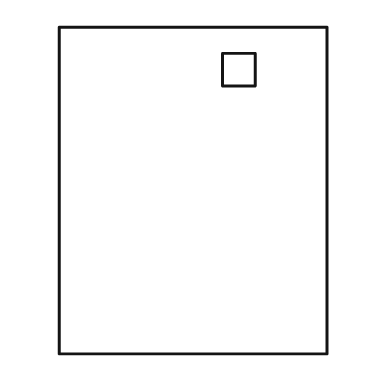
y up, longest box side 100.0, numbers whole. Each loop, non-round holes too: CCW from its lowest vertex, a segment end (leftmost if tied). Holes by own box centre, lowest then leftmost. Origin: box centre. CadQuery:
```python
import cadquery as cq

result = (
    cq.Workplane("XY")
    .moveTo(-41.0, -50.0)
    .lineTo(41.0, -50.0)
    .lineTo(41.0, 50.0)
    .lineTo(-41.0, 50.0)
    .close()
    .moveTo(9.0, 32.0)
    .lineTo(19.0, 32.0)
    .lineTo(19.0, 42.0)
    .lineTo(9.0, 42.0)
    .close()
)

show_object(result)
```